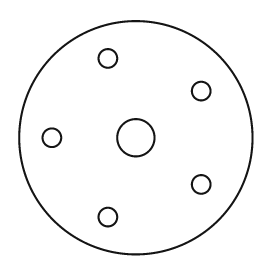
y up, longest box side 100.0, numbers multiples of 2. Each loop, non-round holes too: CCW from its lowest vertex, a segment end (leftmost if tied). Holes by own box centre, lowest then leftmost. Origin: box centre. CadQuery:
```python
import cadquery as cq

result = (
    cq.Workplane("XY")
    .moveTo(0.0, 0.0)
    .circle(50.0)
    .moveTo(-12.0, -34.0)
    .circle(4.0)
    .moveTo(28.0, -20.0)
    .circle(4.0)
    .moveTo(-36.0, 0.0)
    .circle(4.0)
    .moveTo(0.0, 0.0)
    .circle(8.0)
    .moveTo(28.0, 20.0)
    .circle(4.0)
    .moveTo(-12.0, 34.0)
    .circle(4.0)
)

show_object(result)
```